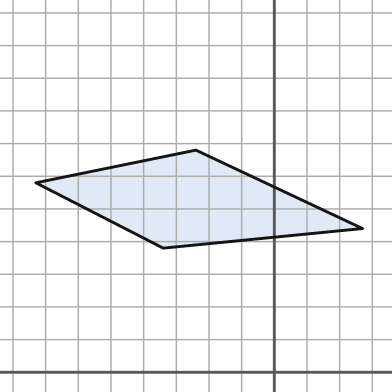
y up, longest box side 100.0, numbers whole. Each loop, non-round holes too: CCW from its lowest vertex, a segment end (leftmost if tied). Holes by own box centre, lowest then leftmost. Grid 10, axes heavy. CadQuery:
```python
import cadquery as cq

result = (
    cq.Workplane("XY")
    .moveTo(-34.0, 38.0)
    .lineTo(27.0, 44.0)
    .lineTo(-24.0, 68.0)
    .lineTo(-73.0, 58.0)
    .close()
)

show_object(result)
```